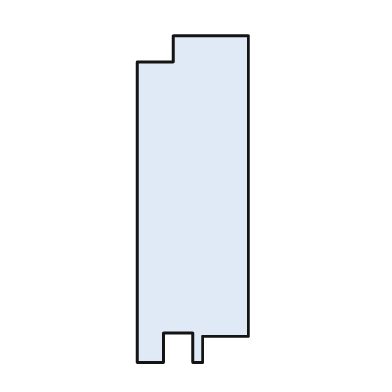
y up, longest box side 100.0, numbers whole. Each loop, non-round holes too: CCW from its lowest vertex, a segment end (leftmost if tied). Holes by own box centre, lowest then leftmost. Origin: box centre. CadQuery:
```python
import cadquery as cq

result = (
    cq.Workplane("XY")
    .moveTo(-17.0, -50.0)
    .lineTo(-9.0, -50.0)
    .lineTo(-9.0, -41.0)
    .lineTo(0.0, -41.0)
    .lineTo(0.0, -50.0)
    .lineTo(3.0, -50.0)
    .lineTo(3.0, -42.0)
    .lineTo(17.0, -42.0)
    .lineTo(17.0, 50.0)
    .lineTo(-6.0, 50.0)
    .lineTo(-6.0, 42.0)
    .lineTo(-17.0, 42.0)
    .close()
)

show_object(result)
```